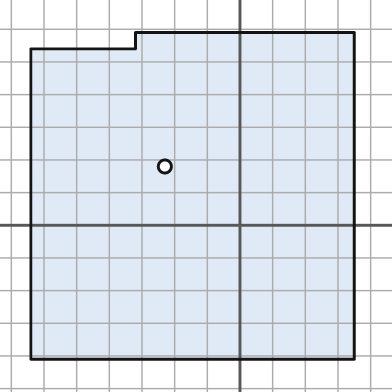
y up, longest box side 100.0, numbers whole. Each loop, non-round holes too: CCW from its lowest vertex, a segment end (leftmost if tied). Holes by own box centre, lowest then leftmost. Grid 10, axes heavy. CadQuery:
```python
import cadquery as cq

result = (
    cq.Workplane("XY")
    .moveTo(-64.0, -41.0)
    .lineTo(35.0, -41.0)
    .lineTo(35.0, 59.0)
    .lineTo(-32.0, 59.0)
    .lineTo(-32.0, 54.0)
    .lineTo(-64.0, 54.0)
    .close()
    .moveTo(-23.0, 18.0)
    .circle(2.0)
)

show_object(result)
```